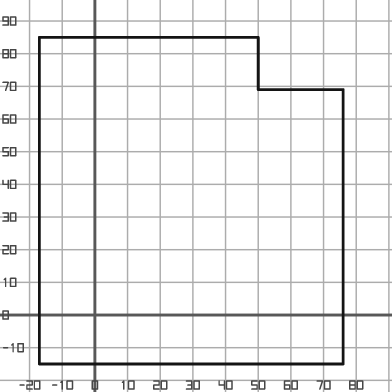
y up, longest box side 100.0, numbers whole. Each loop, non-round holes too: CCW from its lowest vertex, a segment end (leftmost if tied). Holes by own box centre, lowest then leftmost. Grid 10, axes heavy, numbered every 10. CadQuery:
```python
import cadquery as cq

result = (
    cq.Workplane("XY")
    .moveTo(-17.0, -15.0)
    .lineTo(76.0, -15.0)
    .lineTo(76.0, 69.0)
    .lineTo(50.0, 69.0)
    .lineTo(50.0, 85.0)
    .lineTo(-17.0, 85.0)
    .close()
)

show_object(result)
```